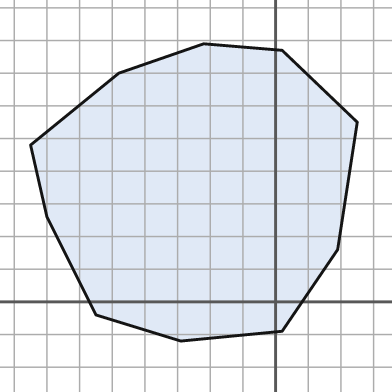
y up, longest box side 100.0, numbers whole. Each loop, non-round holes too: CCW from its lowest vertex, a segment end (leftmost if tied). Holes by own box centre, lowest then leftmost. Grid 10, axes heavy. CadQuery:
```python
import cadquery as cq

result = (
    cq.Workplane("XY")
    .moveTo(-29.0, -12.0)
    .lineTo(2.0, -9.0)
    .lineTo(19.0, 16.0)
    .lineTo(25.0, 55.0)
    .lineTo(2.0, 77.0)
    .lineTo(-22.0, 79.0)
    .lineTo(-48.0, 70.0)
    .lineTo(-75.0, 48.0)
    .lineTo(-70.0, 26.0)
    .lineTo(-55.0, -4.0)
    .close()
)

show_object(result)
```